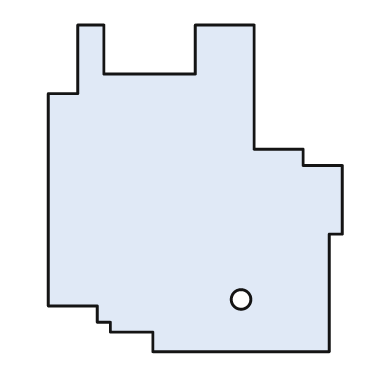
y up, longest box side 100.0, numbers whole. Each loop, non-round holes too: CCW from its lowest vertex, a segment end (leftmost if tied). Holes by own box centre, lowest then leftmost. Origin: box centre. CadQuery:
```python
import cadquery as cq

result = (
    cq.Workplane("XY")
    .moveTo(-13.0, -50.0)
    .lineTo(41.0, -50.0)
    .lineTo(41.0, -14.0)
    .lineTo(45.0, -14.0)
    .lineTo(45.0, 7.0)
    .lineTo(33.0, 7.0)
    .lineTo(33.0, 12.0)
    .lineTo(18.0, 12.0)
    .lineTo(18.0, 50.0)
    .lineTo(0.0, 50.0)
    .lineTo(0.0, 35.0)
    .lineTo(-28.0, 35.0)
    .lineTo(-28.0, 50.0)
    .lineTo(-36.0, 50.0)
    .lineTo(-36.0, 29.0)
    .lineTo(-45.0, 29.0)
    .lineTo(-45.0, -36.0)
    .lineTo(-30.0, -36.0)
    .lineTo(-30.0, -41.0)
    .lineTo(-26.0, -41.0)
    .lineTo(-26.0, -44.0)
    .lineTo(-13.0, -44.0)
    .close()
    .moveTo(14.0, -34.0)
    .circle(3.0)
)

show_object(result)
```